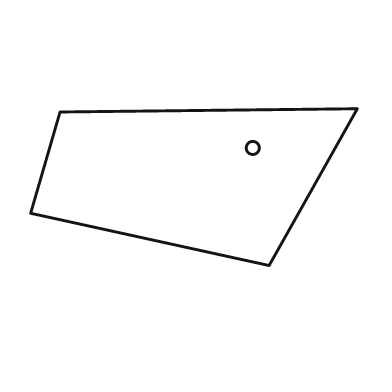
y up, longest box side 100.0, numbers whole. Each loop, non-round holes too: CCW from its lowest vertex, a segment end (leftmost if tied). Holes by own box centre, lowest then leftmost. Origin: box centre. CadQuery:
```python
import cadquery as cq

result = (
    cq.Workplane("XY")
    .moveTo(23.0, -24.0)
    .lineTo(50.0, 24.0)
    .lineTo(-41.0, 23.0)
    .lineTo(-50.0, -8.0)
    .close()
    .moveTo(18.0, 12.0)
    .circle(2.0)
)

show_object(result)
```